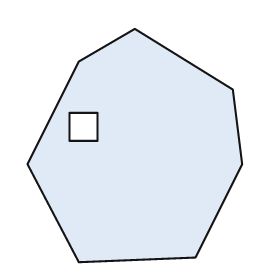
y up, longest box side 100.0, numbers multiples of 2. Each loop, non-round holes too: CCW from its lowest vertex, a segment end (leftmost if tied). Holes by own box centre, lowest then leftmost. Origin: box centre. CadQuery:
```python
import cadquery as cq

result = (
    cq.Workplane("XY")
    .moveTo(-24.0, -50.0)
    .lineTo(26.0, -48.0)
    .lineTo(46.0, -8.0)
    .lineTo(42.0, 24.0)
    .lineTo(0.0, 50.0)
    .lineTo(-24.0, 36.0)
    .lineTo(-46.0, -8.0)
    .close()
    .moveTo(-28.0, 2.0)
    .lineTo(-16.0, 2.0)
    .lineTo(-16.0, 14.0)
    .lineTo(-28.0, 14.0)
    .close()
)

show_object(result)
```